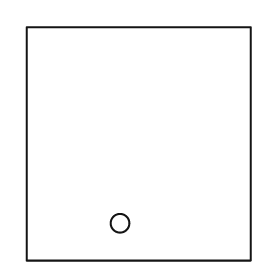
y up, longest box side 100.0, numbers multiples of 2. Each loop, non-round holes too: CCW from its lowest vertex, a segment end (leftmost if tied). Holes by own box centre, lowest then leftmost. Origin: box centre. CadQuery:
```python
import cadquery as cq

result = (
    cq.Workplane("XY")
    .moveTo(-48.0, -50.0)
    .lineTo(48.0, -50.0)
    .lineTo(48.0, 50.0)
    .lineTo(-48.0, 50.0)
    .close()
    .moveTo(-8.0, -34.0)
    .circle(4.0)
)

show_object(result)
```